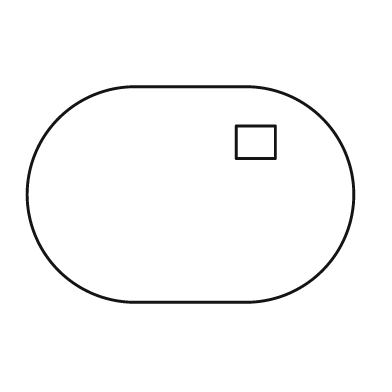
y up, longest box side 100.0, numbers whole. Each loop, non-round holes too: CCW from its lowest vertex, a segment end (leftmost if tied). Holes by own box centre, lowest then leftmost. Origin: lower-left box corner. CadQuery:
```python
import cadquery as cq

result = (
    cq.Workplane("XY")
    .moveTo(33.0, 0.0)
    .lineTo(67.0, 0.0)
    .threePointArc((100.0, 33.0), (67.0, 66.0))
    .lineTo(33.0, 66.0)
    .threePointArc((0.0, 33.0), (33.0, 0.0))
    .close()
    .moveTo(64.0, 44.0)
    .lineTo(76.0, 44.0)
    .lineTo(76.0, 54.0)
    .lineTo(64.0, 54.0)
    .close()
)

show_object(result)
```